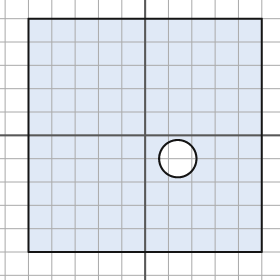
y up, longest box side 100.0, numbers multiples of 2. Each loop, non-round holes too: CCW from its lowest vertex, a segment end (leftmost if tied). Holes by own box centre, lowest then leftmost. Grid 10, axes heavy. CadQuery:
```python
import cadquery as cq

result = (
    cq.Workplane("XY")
    .moveTo(-50.0, -50.0)
    .lineTo(50.0, -50.0)
    .lineTo(50.0, 50.0)
    .lineTo(-50.0, 50.0)
    .close()
    .moveTo(14.0, -10.0)
    .circle(8.0)
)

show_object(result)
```